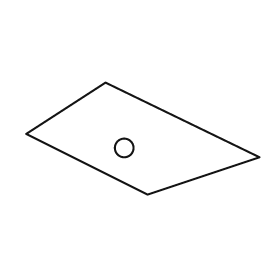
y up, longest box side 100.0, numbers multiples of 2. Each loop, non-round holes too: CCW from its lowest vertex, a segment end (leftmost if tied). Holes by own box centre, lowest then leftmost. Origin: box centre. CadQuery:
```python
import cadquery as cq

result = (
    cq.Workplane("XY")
    .moveTo(2.0, -24.0)
    .lineTo(50.0, -8.0)
    .lineTo(-16.0, 24.0)
    .lineTo(-50.0, 2.0)
    .close()
    .moveTo(-8.0, -4.0)
    .circle(4.0)
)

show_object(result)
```